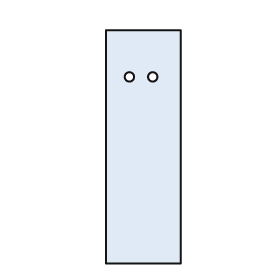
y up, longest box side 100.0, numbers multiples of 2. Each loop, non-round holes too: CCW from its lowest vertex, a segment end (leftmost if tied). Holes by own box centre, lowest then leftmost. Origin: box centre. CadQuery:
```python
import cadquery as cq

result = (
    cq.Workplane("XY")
    .moveTo(-16.0, -50.0)
    .lineTo(16.0, -50.0)
    .lineTo(16.0, 50.0)
    .lineTo(-16.0, 50.0)
    .close()
    .moveTo(-6.0, 30.0)
    .circle(2.0)
    .moveTo(4.0, 30.0)
    .circle(2.0)
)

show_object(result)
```